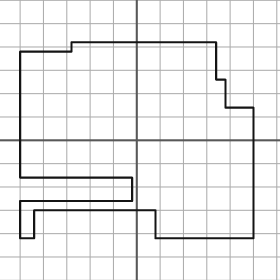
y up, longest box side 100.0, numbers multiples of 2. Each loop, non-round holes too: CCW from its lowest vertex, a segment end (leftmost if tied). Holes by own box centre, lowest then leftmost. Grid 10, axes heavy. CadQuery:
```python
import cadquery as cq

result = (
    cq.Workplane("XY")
    .moveTo(-50.0, -42.0)
    .lineTo(-44.0, -42.0)
    .lineTo(-44.0, -30.0)
    .lineTo(8.0, -30.0)
    .lineTo(8.0, -42.0)
    .lineTo(50.0, -42.0)
    .lineTo(50.0, 14.0)
    .lineTo(38.0, 14.0)
    .lineTo(38.0, 26.0)
    .lineTo(34.0, 26.0)
    .lineTo(34.0, 42.0)
    .lineTo(-28.0, 42.0)
    .lineTo(-28.0, 38.0)
    .lineTo(-50.0, 38.0)
    .lineTo(-50.0, -16.0)
    .lineTo(-2.0, -16.0)
    .lineTo(-2.0, -26.0)
    .lineTo(-50.0, -26.0)
    .close()
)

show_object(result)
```